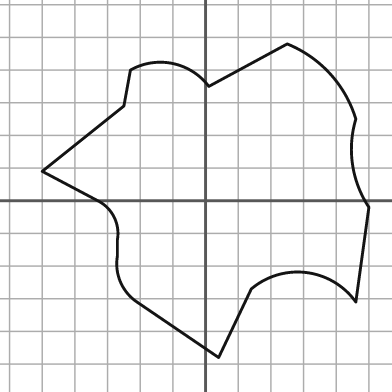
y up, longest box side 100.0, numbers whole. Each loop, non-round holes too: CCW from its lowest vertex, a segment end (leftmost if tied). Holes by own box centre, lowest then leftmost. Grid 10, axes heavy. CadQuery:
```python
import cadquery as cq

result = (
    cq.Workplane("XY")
    .moveTo(4.0, -48.0)
    .lineTo(14.0, -27.0)
    .threePointArc((31.0, -22.0), (46.0, -31.0))
    .lineTo(50.0, -2.0)
    .threePointArc((45.0, 11.0), (46.0, 25.0))
    .threePointArc((38.0, 39.0), (25.0, 48.0))
    .lineTo(1.0, 35.0)
    .threePointArc((-10.0, 42.0), (-23.0, 40.0))
    .lineTo(-25.0, 29.0)
    .lineTo(-50.0, 9.0)
    .lineTo(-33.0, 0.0)
    .threePointArc((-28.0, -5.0), (-27.0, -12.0))
    .lineTo(-27.0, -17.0)
    .threePointArc((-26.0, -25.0), (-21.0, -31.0))
    .close()
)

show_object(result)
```